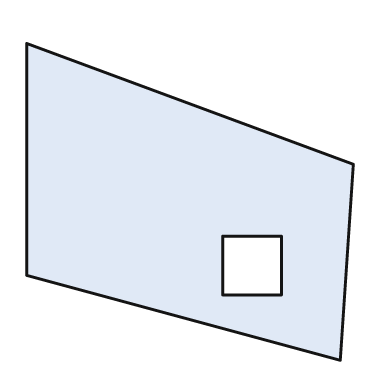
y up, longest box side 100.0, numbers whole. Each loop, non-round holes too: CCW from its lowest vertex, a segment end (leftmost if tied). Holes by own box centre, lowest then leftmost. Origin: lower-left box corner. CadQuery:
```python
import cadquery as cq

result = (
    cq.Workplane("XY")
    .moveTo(96.0, 0.0)
    .lineTo(100.0, 60.0)
    .lineTo(0.0, 97.0)
    .lineTo(0.0, 26.0)
    .close()
    .moveTo(60.0, 20.0)
    .lineTo(78.0, 20.0)
    .lineTo(78.0, 38.0)
    .lineTo(60.0, 38.0)
    .close()
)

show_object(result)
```